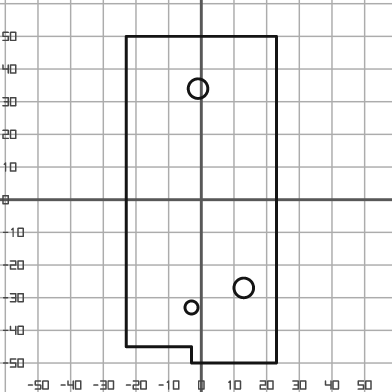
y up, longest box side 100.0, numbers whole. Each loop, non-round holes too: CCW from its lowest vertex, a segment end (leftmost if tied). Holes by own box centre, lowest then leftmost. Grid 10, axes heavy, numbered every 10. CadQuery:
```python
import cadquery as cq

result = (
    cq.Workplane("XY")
    .moveTo(-3.0, -50.0)
    .lineTo(23.0, -50.0)
    .lineTo(23.0, 50.0)
    .lineTo(-23.0, 50.0)
    .lineTo(-23.0, -45.0)
    .lineTo(-3.0, -45.0)
    .close()
    .moveTo(-3.0, -33.0)
    .circle(2.0)
    .moveTo(13.0, -27.0)
    .circle(3.0)
    .moveTo(-1.0, 34.0)
    .circle(3.0)
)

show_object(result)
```